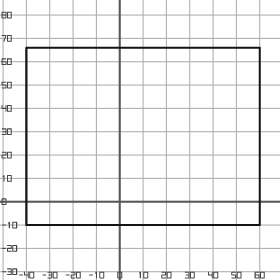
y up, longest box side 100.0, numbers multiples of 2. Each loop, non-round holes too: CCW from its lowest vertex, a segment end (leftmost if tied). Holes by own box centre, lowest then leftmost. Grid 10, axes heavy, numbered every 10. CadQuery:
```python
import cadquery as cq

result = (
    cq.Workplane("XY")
    .moveTo(-40.0, -10.0)
    .lineTo(60.0, -10.0)
    .lineTo(60.0, 66.0)
    .lineTo(-40.0, 66.0)
    .close()
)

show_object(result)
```